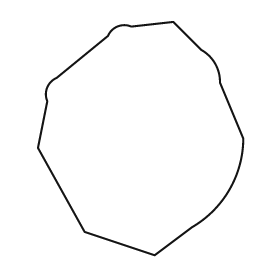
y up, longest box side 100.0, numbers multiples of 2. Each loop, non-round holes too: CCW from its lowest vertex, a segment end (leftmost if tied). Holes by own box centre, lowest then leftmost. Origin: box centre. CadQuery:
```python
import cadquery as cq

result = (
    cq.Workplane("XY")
    .moveTo(6.0, -50.0)
    .lineTo(22.0, -38.0)
    .threePointArc((38.0, -22.0), (44.0, 0.0))
    .lineTo(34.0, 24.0)
    .threePointArc((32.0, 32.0), (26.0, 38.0))
    .lineTo(14.0, 50.0)
    .lineTo(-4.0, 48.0)
    .threePointArc((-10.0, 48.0), (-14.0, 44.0))
    .lineTo(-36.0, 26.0)
    .threePointArc((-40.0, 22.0), (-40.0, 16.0))
    .lineTo(-44.0, -4.0)
    .lineTo(-24.0, -40.0)
    .close()
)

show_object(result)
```